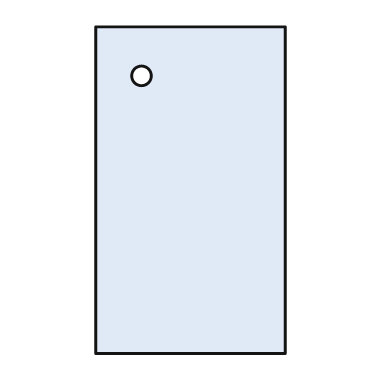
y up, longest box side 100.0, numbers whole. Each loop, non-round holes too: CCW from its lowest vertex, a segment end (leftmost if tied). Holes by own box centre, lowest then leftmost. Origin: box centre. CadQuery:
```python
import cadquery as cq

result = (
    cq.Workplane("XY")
    .moveTo(-29.0, -50.0)
    .lineTo(29.0, -50.0)
    .lineTo(29.0, 50.0)
    .lineTo(-29.0, 50.0)
    .close()
    .moveTo(-15.0, 35.0)
    .circle(3.0)
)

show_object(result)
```